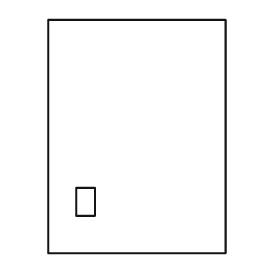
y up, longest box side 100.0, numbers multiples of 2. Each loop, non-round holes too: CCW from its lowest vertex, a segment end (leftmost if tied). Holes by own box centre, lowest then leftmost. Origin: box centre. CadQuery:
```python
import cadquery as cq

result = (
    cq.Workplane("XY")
    .moveTo(-38.0, -50.0)
    .lineTo(38.0, -50.0)
    .lineTo(38.0, 50.0)
    .lineTo(-38.0, 50.0)
    .close()
    .moveTo(-26.0, -34.0)
    .lineTo(-18.0, -34.0)
    .lineTo(-18.0, -22.0)
    .lineTo(-26.0, -22.0)
    .close()
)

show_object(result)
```